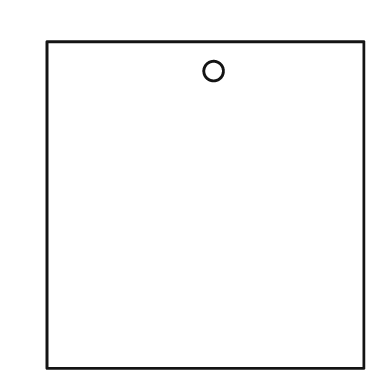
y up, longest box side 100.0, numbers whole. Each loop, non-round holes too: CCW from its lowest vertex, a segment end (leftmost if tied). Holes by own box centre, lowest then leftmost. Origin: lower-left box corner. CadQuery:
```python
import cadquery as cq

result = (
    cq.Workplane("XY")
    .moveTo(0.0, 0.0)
    .lineTo(97.0, 0.0)
    .lineTo(97.0, 100.0)
    .lineTo(0.0, 100.0)
    .close()
    .moveTo(51.0, 91.0)
    .circle(3.0)
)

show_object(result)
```